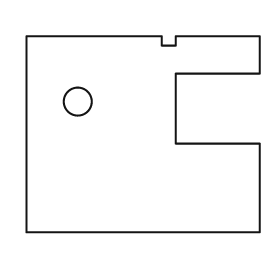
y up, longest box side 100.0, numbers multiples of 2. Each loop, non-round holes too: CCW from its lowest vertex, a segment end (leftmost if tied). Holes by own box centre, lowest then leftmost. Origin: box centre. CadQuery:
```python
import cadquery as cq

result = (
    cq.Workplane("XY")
    .moveTo(-50.0, -42.0)
    .lineTo(50.0, -42.0)
    .lineTo(50.0, -4.0)
    .lineTo(14.0, -4.0)
    .lineTo(14.0, 26.0)
    .lineTo(50.0, 26.0)
    .lineTo(50.0, 42.0)
    .lineTo(14.0, 42.0)
    .lineTo(14.0, 38.0)
    .lineTo(8.0, 38.0)
    .lineTo(8.0, 42.0)
    .lineTo(-50.0, 42.0)
    .close()
    .moveTo(-28.0, 14.0)
    .circle(6.0)
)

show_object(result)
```